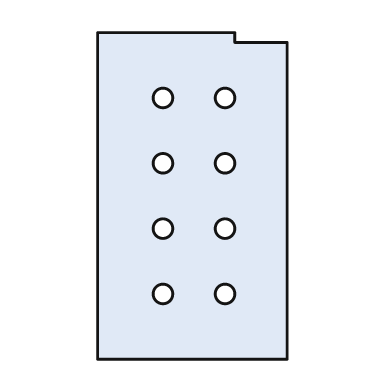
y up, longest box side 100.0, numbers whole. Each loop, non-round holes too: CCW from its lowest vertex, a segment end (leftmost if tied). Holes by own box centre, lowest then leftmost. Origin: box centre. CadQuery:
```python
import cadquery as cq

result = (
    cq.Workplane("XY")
    .moveTo(-29.0, -50.0)
    .lineTo(29.0, -50.0)
    .lineTo(29.0, 47.0)
    .lineTo(13.0, 47.0)
    .lineTo(13.0, 50.0)
    .lineTo(-29.0, 50.0)
    .close()
    .moveTo(-9.0, -30.0)
    .circle(3.0)
    .moveTo(10.0, -30.0)
    .circle(3.0)
    .moveTo(-9.0, -10.0)
    .circle(3.0)
    .moveTo(10.0, -10.0)
    .circle(3.0)
    .moveTo(-9.0, 10.0)
    .circle(3.0)
    .moveTo(10.0, 10.0)
    .circle(3.0)
    .moveTo(-9.0, 30.0)
    .circle(3.0)
    .moveTo(10.0, 30.0)
    .circle(3.0)
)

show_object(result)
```